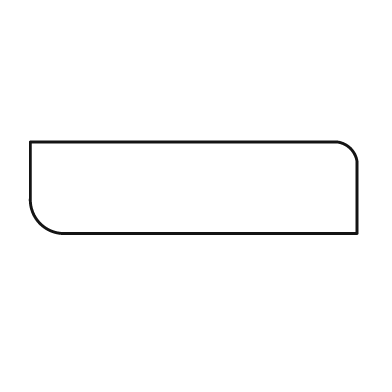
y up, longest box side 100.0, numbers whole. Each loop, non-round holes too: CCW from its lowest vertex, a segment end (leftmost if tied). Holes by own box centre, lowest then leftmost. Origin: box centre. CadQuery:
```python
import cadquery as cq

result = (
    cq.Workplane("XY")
    .moveTo(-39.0, -14.0)
    .lineTo(50.0, -14.0)
    .lineTo(50.0, 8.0)
    .threePointArc((48.0, 12.0), (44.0, 14.0))
    .lineTo(-50.0, 14.0)
    .lineTo(-50.0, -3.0)
    .threePointArc((-47.0, -11.0), (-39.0, -14.0))
    .close()
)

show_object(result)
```